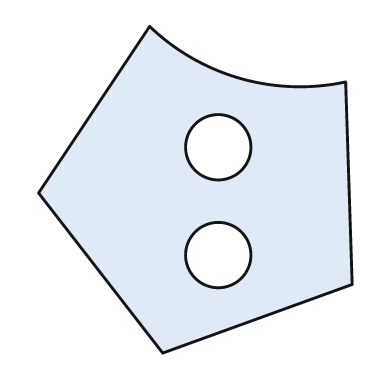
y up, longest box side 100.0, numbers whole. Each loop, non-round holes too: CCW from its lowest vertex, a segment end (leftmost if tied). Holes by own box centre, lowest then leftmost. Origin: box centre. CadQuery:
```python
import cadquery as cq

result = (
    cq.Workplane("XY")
    .moveTo(-10.0, -50.0)
    .lineTo(48.0, -29.0)
    .lineTo(46.0, 33.0)
    .threePointArc((14.0, 34.0), (-14.0, 50.0))
    .lineTo(-48.0, -1.0)
    .close()
    .moveTo(7.0, -20.0)
    .circle(10.0)
    .moveTo(7.0, 13.0)
    .circle(10.0)
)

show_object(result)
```